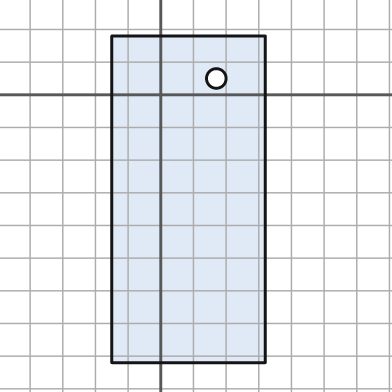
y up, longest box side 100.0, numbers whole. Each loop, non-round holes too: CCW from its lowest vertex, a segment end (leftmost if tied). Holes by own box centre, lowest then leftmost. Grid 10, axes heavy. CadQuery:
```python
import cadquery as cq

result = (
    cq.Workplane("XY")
    .moveTo(-15.0, -82.0)
    .lineTo(32.0, -82.0)
    .lineTo(32.0, 18.0)
    .lineTo(-15.0, 18.0)
    .close()
    .moveTo(17.0, 5.0)
    .circle(3.0)
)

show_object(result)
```